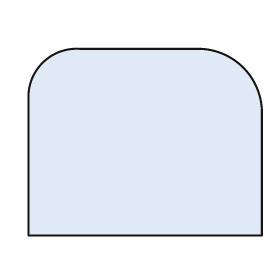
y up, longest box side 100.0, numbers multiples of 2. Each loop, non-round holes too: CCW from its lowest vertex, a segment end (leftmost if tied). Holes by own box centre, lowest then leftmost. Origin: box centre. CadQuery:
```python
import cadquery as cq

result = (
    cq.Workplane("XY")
    .moveTo(-50.0, -40.0)
    .lineTo(50.0, -40.0)
    .lineTo(50.0, 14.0)
    .threePointArc((42.0, 32.0), (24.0, 40.0))
    .lineTo(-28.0, 40.0)
    .threePointArc((-44.0, 34.0), (-50.0, 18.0))
    .close()
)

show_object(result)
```